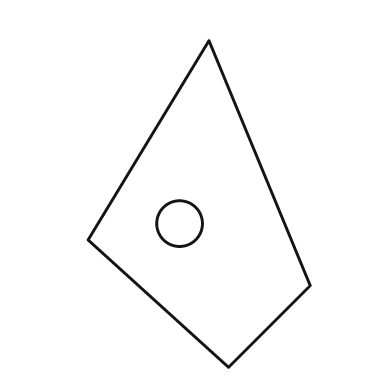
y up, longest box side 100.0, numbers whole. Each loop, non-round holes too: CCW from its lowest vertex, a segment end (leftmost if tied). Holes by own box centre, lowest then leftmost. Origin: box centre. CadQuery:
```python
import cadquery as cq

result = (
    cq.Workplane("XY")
    .moveTo(9.0, -50.0)
    .lineTo(34.0, -25.0)
    .lineTo(3.0, 50.0)
    .lineTo(-34.0, -11.0)
    .close()
    .moveTo(-6.0, -6.0)
    .circle(7.0)
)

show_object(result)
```